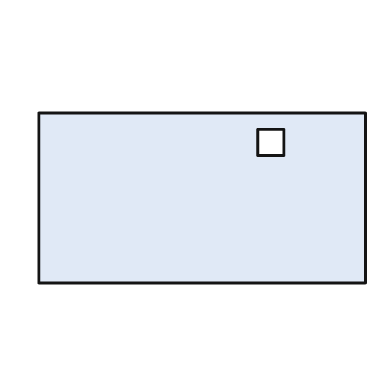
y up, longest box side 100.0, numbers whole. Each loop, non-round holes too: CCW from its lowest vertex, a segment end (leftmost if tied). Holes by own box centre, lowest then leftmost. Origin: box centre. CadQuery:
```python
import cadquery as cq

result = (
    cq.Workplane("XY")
    .moveTo(-50.0, -26.0)
    .lineTo(50.0, -26.0)
    .lineTo(50.0, 26.0)
    .lineTo(-50.0, 26.0)
    .close()
    .moveTo(17.0, 13.0)
    .lineTo(25.0, 13.0)
    .lineTo(25.0, 21.0)
    .lineTo(17.0, 21.0)
    .close()
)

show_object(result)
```